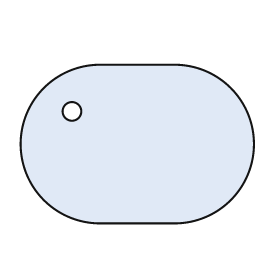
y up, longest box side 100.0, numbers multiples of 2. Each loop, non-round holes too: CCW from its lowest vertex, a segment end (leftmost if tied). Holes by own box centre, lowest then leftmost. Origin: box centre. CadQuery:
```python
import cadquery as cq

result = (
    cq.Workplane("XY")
    .moveTo(-16.0, -34.0)
    .lineTo(16.0, -34.0)
    .threePointArc((50.0, 0.0), (16.0, 34.0))
    .lineTo(-16.0, 34.0)
    .threePointArc((-50.0, 0.0), (-16.0, -34.0))
    .close()
    .moveTo(-28.0, 14.0)
    .circle(4.0)
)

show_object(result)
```